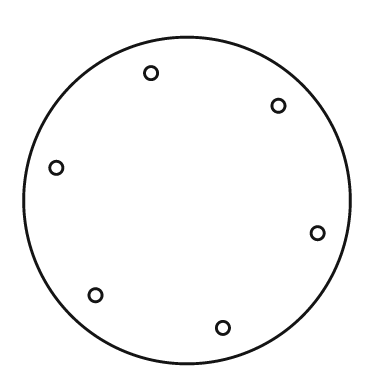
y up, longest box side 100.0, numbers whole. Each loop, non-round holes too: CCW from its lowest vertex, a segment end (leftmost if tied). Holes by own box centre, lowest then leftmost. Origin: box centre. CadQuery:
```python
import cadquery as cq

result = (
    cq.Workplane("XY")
    .moveTo(0.0, 0.0)
    .circle(50.0)
    .moveTo(11.0, -39.0)
    .circle(2.0)
    .moveTo(-28.0, -29.0)
    .circle(2.0)
    .moveTo(40.0, -10.0)
    .circle(2.0)
    .moveTo(-40.0, 10.0)
    .circle(2.0)
    .moveTo(28.0, 29.0)
    .circle(2.0)
    .moveTo(-11.0, 39.0)
    .circle(2.0)
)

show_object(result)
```